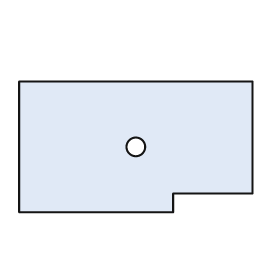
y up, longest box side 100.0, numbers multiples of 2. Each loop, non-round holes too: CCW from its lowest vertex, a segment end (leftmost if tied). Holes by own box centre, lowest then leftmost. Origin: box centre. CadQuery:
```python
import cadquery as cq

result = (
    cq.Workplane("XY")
    .moveTo(-50.0, -28.0)
    .lineTo(16.0, -28.0)
    .lineTo(16.0, -20.0)
    .lineTo(50.0, -20.0)
    .lineTo(50.0, 28.0)
    .lineTo(-50.0, 28.0)
    .close()
    .moveTo(0.0, 0.0)
    .circle(4.0)
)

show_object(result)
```